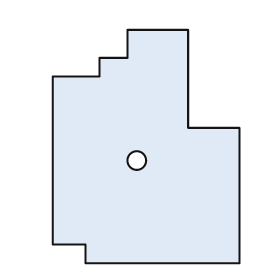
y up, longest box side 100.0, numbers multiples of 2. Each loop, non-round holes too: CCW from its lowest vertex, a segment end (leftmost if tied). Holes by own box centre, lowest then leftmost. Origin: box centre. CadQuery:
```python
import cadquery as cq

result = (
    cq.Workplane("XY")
    .moveTo(-26.0, -50.0)
    .lineTo(40.0, -50.0)
    .lineTo(40.0, 8.0)
    .lineTo(18.0, 8.0)
    .lineTo(18.0, 50.0)
    .lineTo(-8.0, 50.0)
    .lineTo(-8.0, 38.0)
    .lineTo(-20.0, 38.0)
    .lineTo(-20.0, 30.0)
    .lineTo(-40.0, 30.0)
    .lineTo(-40.0, -42.0)
    .lineTo(-26.0, -42.0)
    .close()
    .moveTo(-4.0, -6.0)
    .circle(4.0)
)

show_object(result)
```